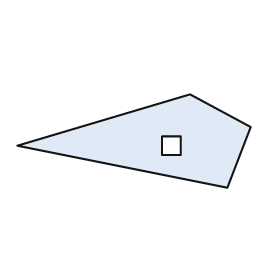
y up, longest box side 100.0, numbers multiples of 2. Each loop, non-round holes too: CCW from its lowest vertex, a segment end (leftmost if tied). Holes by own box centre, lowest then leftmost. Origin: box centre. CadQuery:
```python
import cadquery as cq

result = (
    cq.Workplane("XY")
    .moveTo(40.0, -20.0)
    .lineTo(50.0, 6.0)
    .lineTo(24.0, 20.0)
    .lineTo(-50.0, -2.0)
    .close()
    .moveTo(12.0, -6.0)
    .lineTo(20.0, -6.0)
    .lineTo(20.0, 2.0)
    .lineTo(12.0, 2.0)
    .close()
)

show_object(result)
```